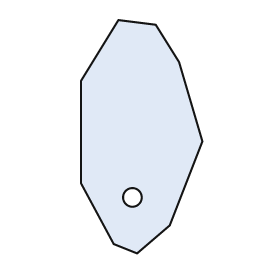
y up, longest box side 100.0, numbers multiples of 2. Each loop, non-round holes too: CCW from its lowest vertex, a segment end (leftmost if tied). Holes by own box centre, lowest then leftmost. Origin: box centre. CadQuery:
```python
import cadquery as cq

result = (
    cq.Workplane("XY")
    .moveTo(-2.0, -50.0)
    .lineTo(12.0, -38.0)
    .lineTo(26.0, -2.0)
    .lineTo(16.0, 32.0)
    .lineTo(6.0, 48.0)
    .lineTo(-10.0, 50.0)
    .lineTo(-26.0, 24.0)
    .lineTo(-26.0, -20.0)
    .lineTo(-12.0, -46.0)
    .close()
    .moveTo(-4.0, -26.0)
    .circle(4.0)
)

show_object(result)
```